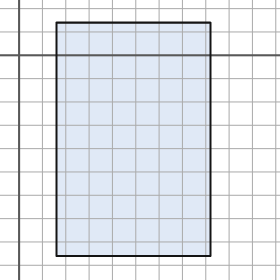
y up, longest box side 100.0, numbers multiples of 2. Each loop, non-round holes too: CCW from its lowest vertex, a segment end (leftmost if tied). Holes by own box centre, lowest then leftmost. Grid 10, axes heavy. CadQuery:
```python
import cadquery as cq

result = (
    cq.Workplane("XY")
    .moveTo(16.0, -86.0)
    .lineTo(82.0, -86.0)
    .lineTo(82.0, 14.0)
    .lineTo(16.0, 14.0)
    .close()
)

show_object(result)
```